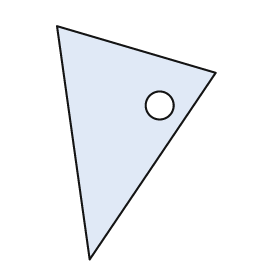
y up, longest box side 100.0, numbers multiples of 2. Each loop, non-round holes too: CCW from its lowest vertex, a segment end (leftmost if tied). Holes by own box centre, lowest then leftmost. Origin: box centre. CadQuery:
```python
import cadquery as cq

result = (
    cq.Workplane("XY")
    .moveTo(-20.0, -50.0)
    .lineTo(34.0, 30.0)
    .lineTo(-34.0, 50.0)
    .close()
    .moveTo(10.0, 16.0)
    .circle(6.0)
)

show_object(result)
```